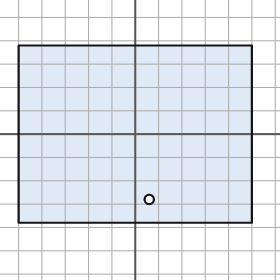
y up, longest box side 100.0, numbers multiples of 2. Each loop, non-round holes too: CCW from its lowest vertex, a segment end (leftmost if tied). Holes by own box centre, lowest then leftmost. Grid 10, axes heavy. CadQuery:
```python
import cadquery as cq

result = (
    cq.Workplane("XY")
    .moveTo(-50.0, -38.0)
    .lineTo(50.0, -38.0)
    .lineTo(50.0, 38.0)
    .lineTo(-50.0, 38.0)
    .close()
    .moveTo(6.0, -28.0)
    .circle(2.0)
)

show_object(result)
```